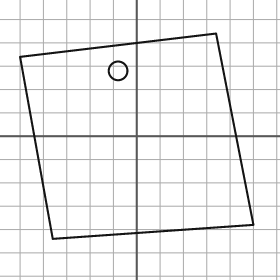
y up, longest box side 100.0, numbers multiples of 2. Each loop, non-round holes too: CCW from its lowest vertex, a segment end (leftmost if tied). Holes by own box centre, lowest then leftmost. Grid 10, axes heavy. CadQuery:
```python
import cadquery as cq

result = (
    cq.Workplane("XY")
    .moveTo(-36.0, -44.0)
    .lineTo(50.0, -38.0)
    .lineTo(34.0, 44.0)
    .lineTo(-50.0, 34.0)
    .close()
    .moveTo(-8.0, 28.0)
    .circle(4.0)
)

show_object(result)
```